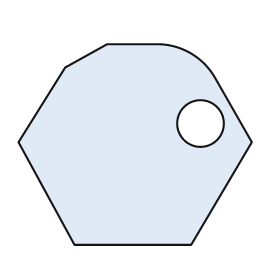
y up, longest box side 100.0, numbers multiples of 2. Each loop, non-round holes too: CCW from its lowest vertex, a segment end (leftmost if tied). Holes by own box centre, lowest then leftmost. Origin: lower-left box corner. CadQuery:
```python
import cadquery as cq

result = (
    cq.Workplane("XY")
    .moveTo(24.0, 0.0)
    .lineTo(74.0, 0.0)
    .lineTo(100.0, 44.0)
    .lineTo(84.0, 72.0)
    .threePointArc((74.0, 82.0), (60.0, 86.0))
    .lineTo(38.0, 86.0)
    .lineTo(20.0, 76.0)
    .lineTo(0.0, 44.0)
    .close()
    .moveTo(78.0, 52.0)
    .circle(10.0)
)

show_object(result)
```